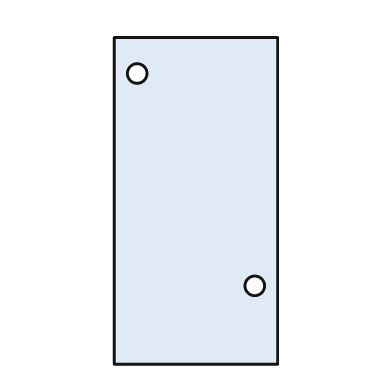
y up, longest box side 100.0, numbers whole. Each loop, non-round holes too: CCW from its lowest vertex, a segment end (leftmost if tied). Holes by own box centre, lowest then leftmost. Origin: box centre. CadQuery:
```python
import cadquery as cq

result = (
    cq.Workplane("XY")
    .moveTo(-25.0, -50.0)
    .lineTo(25.0, -50.0)
    .lineTo(25.0, 50.0)
    .lineTo(-25.0, 50.0)
    .close()
    .moveTo(18.0, -26.0)
    .circle(3.0)
    .moveTo(-18.0, 39.0)
    .circle(3.0)
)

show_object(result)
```